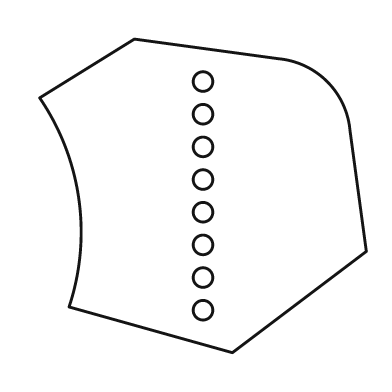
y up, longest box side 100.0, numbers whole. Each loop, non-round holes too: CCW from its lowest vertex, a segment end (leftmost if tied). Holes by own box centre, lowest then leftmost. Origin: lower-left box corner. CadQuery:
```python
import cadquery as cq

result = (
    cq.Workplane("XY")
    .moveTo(59.0, 0.0)
    .lineTo(100.0, 31.0)
    .lineTo(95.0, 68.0)
    .threePointArc((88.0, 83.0), (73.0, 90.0))
    .lineTo(29.0, 96.0)
    .lineTo(0.0, 78.0)
    .threePointArc((12.0, 47.0), (9.0, 14.0))
    .close()
    .moveTo(50.0, 13.0)
    .circle(3.0)
    .moveTo(50.0, 23.0)
    .circle(3.0)
    .moveTo(50.0, 33.0)
    .circle(3.0)
    .moveTo(50.0, 43.0)
    .circle(3.0)
    .moveTo(50.0, 53.0)
    .circle(3.0)
    .moveTo(50.0, 63.0)
    .circle(3.0)
    .moveTo(50.0, 73.0)
    .circle(3.0)
    .moveTo(50.0, 83.0)
    .circle(3.0)
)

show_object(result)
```